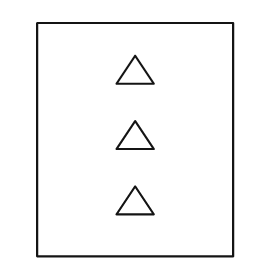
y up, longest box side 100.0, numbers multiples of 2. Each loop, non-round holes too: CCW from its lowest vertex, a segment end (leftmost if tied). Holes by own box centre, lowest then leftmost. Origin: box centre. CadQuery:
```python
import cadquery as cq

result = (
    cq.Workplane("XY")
    .moveTo(-42.0, -50.0)
    .lineTo(42.0, -50.0)
    .lineTo(42.0, 50.0)
    .lineTo(-42.0, 50.0)
    .close()
    .moveTo(-8.0, -32.0)
    .lineTo(8.0, -32.0)
    .lineTo(0.0, -20.0)
    .close()
    .moveTo(-8.0, -4.0)
    .lineTo(8.0, -4.0)
    .lineTo(0.0, 8.0)
    .close()
    .moveTo(-8.0, 24.0)
    .lineTo(8.0, 24.0)
    .lineTo(0.0, 36.0)
    .close()
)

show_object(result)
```